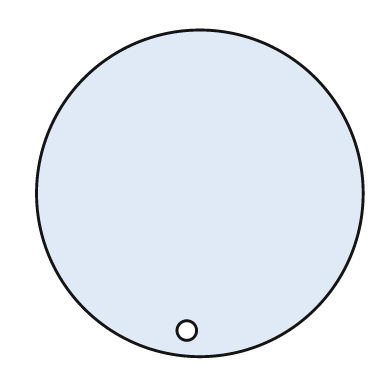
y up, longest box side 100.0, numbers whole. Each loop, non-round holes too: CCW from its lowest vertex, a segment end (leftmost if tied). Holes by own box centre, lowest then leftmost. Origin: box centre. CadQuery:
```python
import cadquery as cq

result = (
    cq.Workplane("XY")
    .moveTo(0.0, 0.0)
    .circle(50.0)
    .moveTo(-4.0, -42.0)
    .circle(3.0)
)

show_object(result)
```